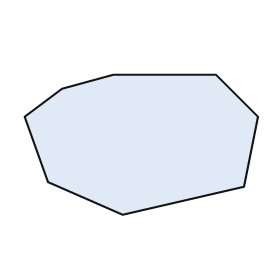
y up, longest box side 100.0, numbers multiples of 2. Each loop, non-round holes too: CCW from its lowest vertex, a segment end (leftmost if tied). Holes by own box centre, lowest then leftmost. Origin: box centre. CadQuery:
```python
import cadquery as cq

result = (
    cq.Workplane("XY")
    .moveTo(-8.0, -30.0)
    .lineTo(44.0, -18.0)
    .lineTo(50.0, 12.0)
    .lineTo(32.0, 30.0)
    .lineTo(-12.0, 30.0)
    .lineTo(-34.0, 24.0)
    .lineTo(-50.0, 12.0)
    .lineTo(-40.0, -16.0)
    .close()
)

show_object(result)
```